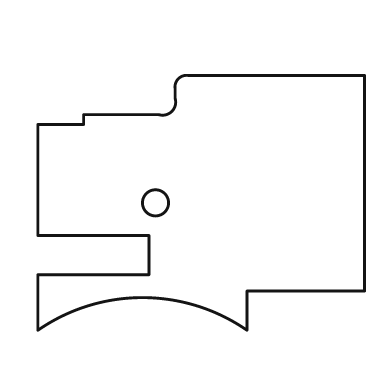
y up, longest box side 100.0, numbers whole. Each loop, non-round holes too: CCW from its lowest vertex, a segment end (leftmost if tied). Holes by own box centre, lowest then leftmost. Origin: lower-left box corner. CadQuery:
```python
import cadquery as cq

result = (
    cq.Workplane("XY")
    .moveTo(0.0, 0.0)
    .threePointArc((32.0, 10.0), (64.0, 0.0))
    .lineTo(64.0, 12.0)
    .lineTo(100.0, 12.0)
    .lineTo(100.0, 78.0)
    .lineTo(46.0, 78.0)
    .threePointArc((43.0, 77.0), (42.0, 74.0))
    .lineTo(42.0, 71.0)
    .threePointArc((41.0, 67.0), (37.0, 66.0))
    .lineTo(14.0, 66.0)
    .lineTo(14.0, 63.0)
    .lineTo(0.0, 63.0)
    .lineTo(0.0, 29.0)
    .lineTo(34.0, 29.0)
    .lineTo(34.0, 17.0)
    .lineTo(0.0, 17.0)
    .close()
    .moveTo(36.0, 39.0)
    .circle(4.0)
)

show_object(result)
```